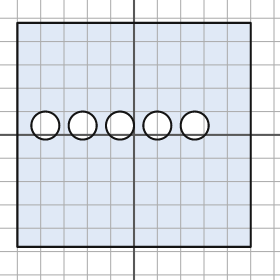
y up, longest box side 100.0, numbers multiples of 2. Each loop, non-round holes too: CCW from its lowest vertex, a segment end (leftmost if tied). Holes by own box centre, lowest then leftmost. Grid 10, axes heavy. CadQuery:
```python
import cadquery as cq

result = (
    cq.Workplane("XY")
    .moveTo(-50.0, -48.0)
    .lineTo(50.0, -48.0)
    .lineTo(50.0, 48.0)
    .lineTo(-50.0, 48.0)
    .close()
    .moveTo(-38.0, 4.0)
    .circle(6.0)
    .moveTo(-22.0, 4.0)
    .circle(6.0)
    .moveTo(-6.0, 4.0)
    .circle(6.0)
    .moveTo(10.0, 4.0)
    .circle(6.0)
    .moveTo(26.0, 4.0)
    .circle(6.0)
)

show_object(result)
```